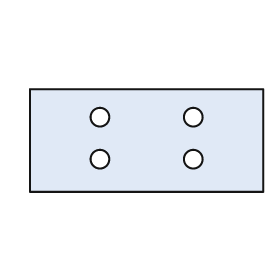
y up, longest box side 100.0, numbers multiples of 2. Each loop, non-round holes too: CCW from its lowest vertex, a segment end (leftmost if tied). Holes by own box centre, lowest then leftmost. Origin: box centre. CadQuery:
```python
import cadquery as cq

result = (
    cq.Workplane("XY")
    .moveTo(-50.0, -22.0)
    .lineTo(50.0, -22.0)
    .lineTo(50.0, 22.0)
    .lineTo(-50.0, 22.0)
    .close()
    .moveTo(-20.0, -8.0)
    .circle(4.0)
    .moveTo(20.0, -8.0)
    .circle(4.0)
    .moveTo(-20.0, 10.0)
    .circle(4.0)
    .moveTo(20.0, 10.0)
    .circle(4.0)
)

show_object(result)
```